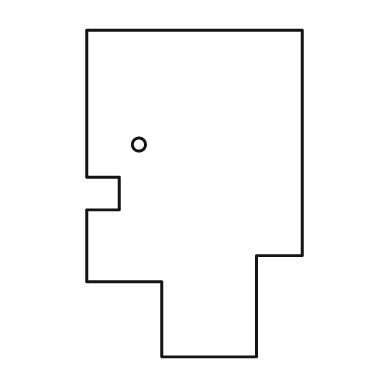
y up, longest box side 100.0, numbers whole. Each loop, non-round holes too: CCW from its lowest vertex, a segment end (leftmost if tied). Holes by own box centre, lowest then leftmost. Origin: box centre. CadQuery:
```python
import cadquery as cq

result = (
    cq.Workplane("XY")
    .moveTo(-10.0, -50.0)
    .lineTo(19.0, -50.0)
    .lineTo(19.0, -19.0)
    .lineTo(33.0, -19.0)
    .lineTo(33.0, 50.0)
    .lineTo(-33.0, 50.0)
    .lineTo(-33.0, 5.0)
    .lineTo(-23.0, 5.0)
    .lineTo(-23.0, -5.0)
    .lineTo(-33.0, -5.0)
    .lineTo(-33.0, -27.0)
    .lineTo(-10.0, -27.0)
    .close()
    .moveTo(-17.0, 15.0)
    .circle(2.0)
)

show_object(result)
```